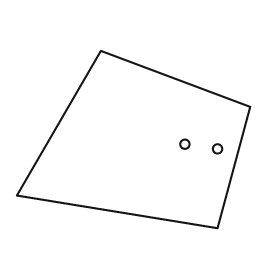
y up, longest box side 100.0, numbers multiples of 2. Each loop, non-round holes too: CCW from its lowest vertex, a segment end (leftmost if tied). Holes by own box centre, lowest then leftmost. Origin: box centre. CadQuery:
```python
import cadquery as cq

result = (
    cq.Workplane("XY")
    .moveTo(36.0, -38.0)
    .lineTo(50.0, 14.0)
    .lineTo(-14.0, 38.0)
    .lineTo(-50.0, -24.0)
    .close()
    .moveTo(36.0, -4.0)
    .circle(2.0)
    .moveTo(22.0, -2.0)
    .circle(2.0)
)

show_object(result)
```